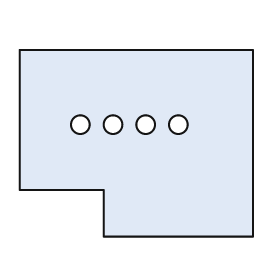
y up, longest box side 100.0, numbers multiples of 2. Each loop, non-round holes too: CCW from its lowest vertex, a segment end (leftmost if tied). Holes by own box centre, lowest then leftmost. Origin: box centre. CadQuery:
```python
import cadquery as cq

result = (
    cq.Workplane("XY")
    .moveTo(-14.0, -40.0)
    .lineTo(50.0, -40.0)
    .lineTo(50.0, 40.0)
    .lineTo(-50.0, 40.0)
    .lineTo(-50.0, -20.0)
    .lineTo(-14.0, -20.0)
    .close()
    .moveTo(-24.0, 8.0)
    .circle(4.0)
    .moveTo(-10.0, 8.0)
    .circle(4.0)
    .moveTo(4.0, 8.0)
    .circle(4.0)
    .moveTo(18.0, 8.0)
    .circle(4.0)
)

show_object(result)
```